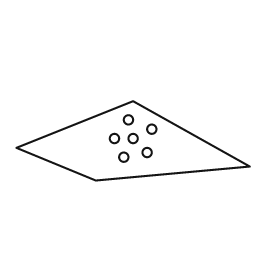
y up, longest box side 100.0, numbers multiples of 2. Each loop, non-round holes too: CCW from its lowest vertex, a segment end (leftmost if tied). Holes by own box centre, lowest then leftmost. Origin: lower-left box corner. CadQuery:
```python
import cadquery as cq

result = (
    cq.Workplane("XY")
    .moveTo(34.0, 0.0)
    .lineTo(100.0, 6.0)
    .lineTo(50.0, 34.0)
    .lineTo(0.0, 14.0)
    .close()
    .moveTo(46.0, 10.0)
    .circle(2.0)
    .moveTo(56.0, 12.0)
    .circle(2.0)
    .moveTo(42.0, 18.0)
    .circle(2.0)
    .moveTo(50.0, 18.0)
    .circle(2.0)
    .moveTo(58.0, 22.0)
    .circle(2.0)
    .moveTo(48.0, 26.0)
    .circle(2.0)
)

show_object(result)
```